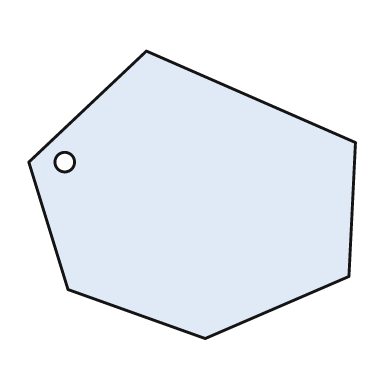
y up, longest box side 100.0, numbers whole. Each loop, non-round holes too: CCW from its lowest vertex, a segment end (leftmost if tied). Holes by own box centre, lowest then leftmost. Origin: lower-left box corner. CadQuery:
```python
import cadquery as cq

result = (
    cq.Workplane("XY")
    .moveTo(54.0, 0.0)
    .lineTo(98.0, 19.0)
    .lineTo(100.0, 60.0)
    .lineTo(36.0, 88.0)
    .lineTo(0.0, 54.0)
    .lineTo(12.0, 15.0)
    .close()
    .moveTo(11.0, 54.0)
    .circle(3.0)
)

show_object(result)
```